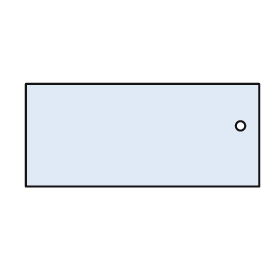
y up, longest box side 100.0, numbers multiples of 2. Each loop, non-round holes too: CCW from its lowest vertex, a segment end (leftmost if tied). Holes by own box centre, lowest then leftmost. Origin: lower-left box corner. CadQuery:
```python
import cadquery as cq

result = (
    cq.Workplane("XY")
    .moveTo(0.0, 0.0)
    .lineTo(100.0, 0.0)
    .lineTo(100.0, 44.0)
    .lineTo(0.0, 44.0)
    .close()
    .moveTo(92.0, 26.0)
    .circle(2.0)
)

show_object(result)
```